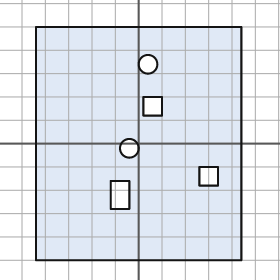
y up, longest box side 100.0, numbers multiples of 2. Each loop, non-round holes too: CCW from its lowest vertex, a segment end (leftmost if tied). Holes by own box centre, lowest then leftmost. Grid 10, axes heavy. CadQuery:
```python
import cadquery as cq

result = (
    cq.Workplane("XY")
    .moveTo(-44.0, -50.0)
    .lineTo(44.0, -50.0)
    .lineTo(44.0, 50.0)
    .lineTo(-44.0, 50.0)
    .close()
    .moveTo(-12.0, -28.0)
    .lineTo(-4.0, -28.0)
    .lineTo(-4.0, -16.0)
    .lineTo(-12.0, -16.0)
    .close()
    .moveTo(26.0, -18.0)
    .lineTo(34.0, -18.0)
    .lineTo(34.0, -10.0)
    .lineTo(26.0, -10.0)
    .close()
    .moveTo(-4.0, -2.0)
    .circle(4.0)
    .moveTo(2.0, 12.0)
    .lineTo(10.0, 12.0)
    .lineTo(10.0, 20.0)
    .lineTo(2.0, 20.0)
    .close()
    .moveTo(4.0, 34.0)
    .circle(4.0)
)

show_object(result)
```